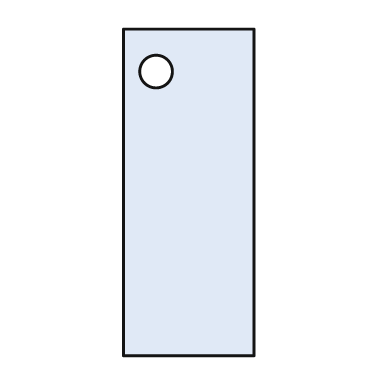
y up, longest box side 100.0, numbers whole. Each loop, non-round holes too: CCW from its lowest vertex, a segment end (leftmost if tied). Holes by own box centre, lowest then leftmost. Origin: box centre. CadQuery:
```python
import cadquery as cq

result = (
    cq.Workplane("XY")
    .moveTo(-20.0, -50.0)
    .lineTo(20.0, -50.0)
    .lineTo(20.0, 50.0)
    .lineTo(-20.0, 50.0)
    .close()
    .moveTo(-10.0, 37.0)
    .circle(5.0)
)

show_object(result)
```